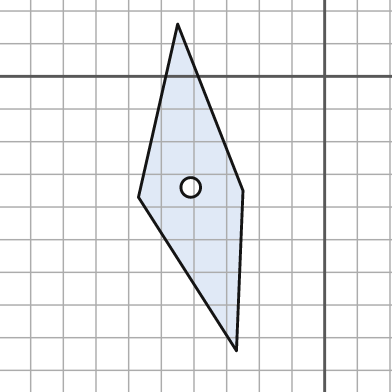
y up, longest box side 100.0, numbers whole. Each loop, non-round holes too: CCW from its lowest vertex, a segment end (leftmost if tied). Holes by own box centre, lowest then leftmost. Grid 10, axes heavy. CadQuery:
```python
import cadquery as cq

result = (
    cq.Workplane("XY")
    .moveTo(-27.0, -84.0)
    .lineTo(-25.0, -35.0)
    .lineTo(-45.0, 16.0)
    .lineTo(-57.0, -37.0)
    .close()
    .moveTo(-41.0, -34.0)
    .circle(3.0)
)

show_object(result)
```